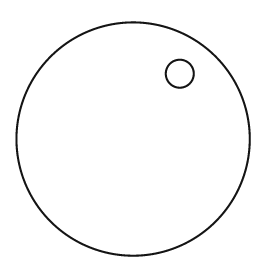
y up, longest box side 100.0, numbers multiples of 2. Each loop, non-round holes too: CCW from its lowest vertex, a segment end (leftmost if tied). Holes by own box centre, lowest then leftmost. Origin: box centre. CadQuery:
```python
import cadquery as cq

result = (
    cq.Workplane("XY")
    .moveTo(0.0, 0.0)
    .circle(50.0)
    .moveTo(20.0, 28.0)
    .circle(6.0)
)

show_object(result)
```